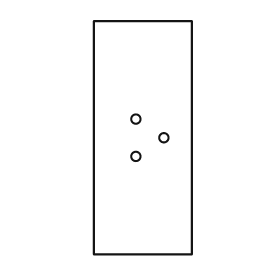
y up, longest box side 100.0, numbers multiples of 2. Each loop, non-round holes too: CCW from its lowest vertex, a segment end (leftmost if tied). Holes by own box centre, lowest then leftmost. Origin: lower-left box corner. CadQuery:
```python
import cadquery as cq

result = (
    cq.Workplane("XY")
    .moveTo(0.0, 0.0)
    .lineTo(42.0, 0.0)
    .lineTo(42.0, 100.0)
    .lineTo(0.0, 100.0)
    .close()
    .moveTo(18.0, 42.0)
    .circle(2.0)
    .moveTo(30.0, 50.0)
    .circle(2.0)
    .moveTo(18.0, 58.0)
    .circle(2.0)
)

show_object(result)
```